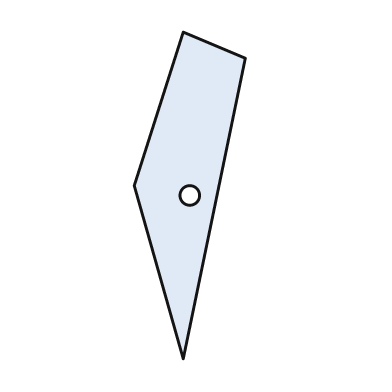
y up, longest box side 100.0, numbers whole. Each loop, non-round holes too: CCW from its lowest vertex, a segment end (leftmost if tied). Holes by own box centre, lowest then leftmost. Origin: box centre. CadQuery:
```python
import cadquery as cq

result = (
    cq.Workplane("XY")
    .moveTo(-2.0, -50.0)
    .lineTo(17.0, 42.0)
    .lineTo(-2.0, 50.0)
    .lineTo(-17.0, 3.0)
    .close()
    .moveTo(0.0, 0.0)
    .circle(3.0)
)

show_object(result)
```